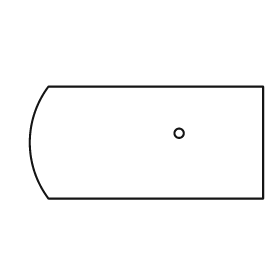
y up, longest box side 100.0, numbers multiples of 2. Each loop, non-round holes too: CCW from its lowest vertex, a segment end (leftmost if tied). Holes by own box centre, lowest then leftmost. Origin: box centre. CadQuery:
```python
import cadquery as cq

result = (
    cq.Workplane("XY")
    .moveTo(-42.0, -24.0)
    .lineTo(50.0, -24.0)
    .lineTo(50.0, 24.0)
    .lineTo(-42.0, 24.0)
    .threePointArc((-50.0, 0.0), (-42.0, -24.0))
    .close()
    .moveTo(14.0, 4.0)
    .circle(2.0)
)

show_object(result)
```